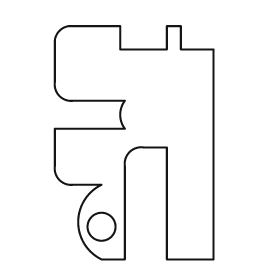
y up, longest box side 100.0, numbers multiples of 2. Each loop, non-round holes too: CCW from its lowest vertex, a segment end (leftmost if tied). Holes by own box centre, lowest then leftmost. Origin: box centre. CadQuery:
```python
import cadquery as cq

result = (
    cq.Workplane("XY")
    .moveTo(-14.0, -50.0)
    .lineTo(-4.0, -50.0)
    .lineTo(-4.0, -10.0)
    .threePointArc((-2.0, -4.0), (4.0, -2.0))
    .lineTo(14.0, -2.0)
    .lineTo(14.0, -50.0)
    .lineTo(34.0, -50.0)
    .lineTo(34.0, 40.0)
    .lineTo(20.0, 40.0)
    .lineTo(20.0, 50.0)
    .lineTo(14.0, 50.0)
    .lineTo(14.0, 40.0)
    .lineTo(-6.0, 40.0)
    .lineTo(-6.0, 50.0)
    .lineTo(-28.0, 50.0)
    .threePointArc((-32.0, 48.0), (-34.0, 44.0))
    .lineTo(-34.0, 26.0)
    .threePointArc((-32.0, 20.0), (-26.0, 18.0))
    .lineTo(-4.0, 18.0)
    .threePointArc((-6.0, 12.0), (-4.0, 6.0))
    .lineTo(-34.0, 6.0)
    .lineTo(-34.0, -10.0)
    .threePointArc((-32.0, -16.0), (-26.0, -18.0))
    .lineTo(-14.0, -18.0)
    .threePointArc((-24.0, -34.0), (-14.0, -50.0))
    .close()
    .moveTo(-14.0, -36.0)
    .circle(6.0)
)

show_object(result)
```